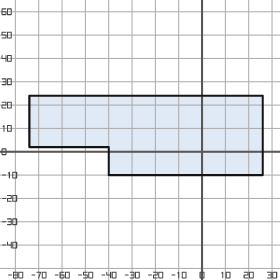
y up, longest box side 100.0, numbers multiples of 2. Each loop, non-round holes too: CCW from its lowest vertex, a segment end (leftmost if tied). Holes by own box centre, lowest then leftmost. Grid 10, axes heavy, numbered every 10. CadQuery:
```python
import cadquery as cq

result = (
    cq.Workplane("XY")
    .moveTo(-40.0, -10.0)
    .lineTo(26.0, -10.0)
    .lineTo(26.0, 24.0)
    .lineTo(-74.0, 24.0)
    .lineTo(-74.0, 2.0)
    .lineTo(-40.0, 2.0)
    .close()
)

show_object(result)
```